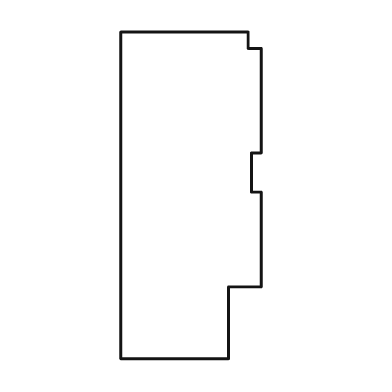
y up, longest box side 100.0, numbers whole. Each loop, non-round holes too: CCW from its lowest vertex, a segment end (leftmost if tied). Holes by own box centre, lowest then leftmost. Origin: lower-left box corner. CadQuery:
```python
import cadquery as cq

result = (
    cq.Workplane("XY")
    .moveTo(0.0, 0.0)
    .lineTo(33.0, 0.0)
    .lineTo(33.0, 22.0)
    .lineTo(43.0, 22.0)
    .lineTo(43.0, 51.0)
    .lineTo(40.0, 51.0)
    .lineTo(40.0, 63.0)
    .lineTo(43.0, 63.0)
    .lineTo(43.0, 95.0)
    .lineTo(39.0, 95.0)
    .lineTo(39.0, 100.0)
    .lineTo(0.0, 100.0)
    .close()
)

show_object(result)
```